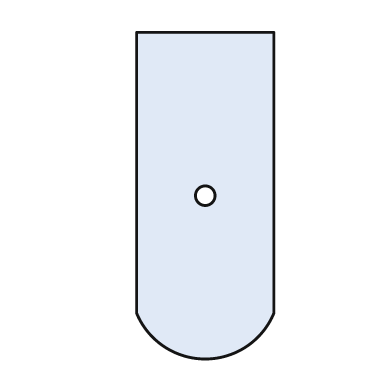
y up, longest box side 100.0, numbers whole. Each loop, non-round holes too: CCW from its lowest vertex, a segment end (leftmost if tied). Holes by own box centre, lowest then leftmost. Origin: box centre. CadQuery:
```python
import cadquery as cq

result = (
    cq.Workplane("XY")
    .moveTo(-21.0, -36.0)
    .threePointArc((0.0, -50.0), (21.0, -36.0))
    .lineTo(21.0, 50.0)
    .lineTo(-21.0, 50.0)
    .close()
    .moveTo(0.0, 0.0)
    .circle(3.0)
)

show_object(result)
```